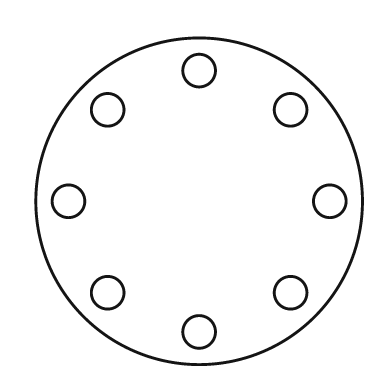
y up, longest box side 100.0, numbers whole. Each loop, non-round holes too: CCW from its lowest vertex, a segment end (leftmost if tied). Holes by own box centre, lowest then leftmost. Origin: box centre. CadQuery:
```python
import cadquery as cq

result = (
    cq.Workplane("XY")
    .moveTo(0.0, 0.0)
    .circle(50.0)
    .moveTo(0.0, -40.0)
    .circle(5.0)
    .moveTo(-28.0, -28.0)
    .circle(5.0)
    .moveTo(28.0, -28.0)
    .circle(5.0)
    .moveTo(-40.0, 0.0)
    .circle(5.0)
    .moveTo(40.0, 0.0)
    .circle(5.0)
    .moveTo(-28.0, 28.0)
    .circle(5.0)
    .moveTo(28.0, 28.0)
    .circle(5.0)
    .moveTo(0.0, 40.0)
    .circle(5.0)
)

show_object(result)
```